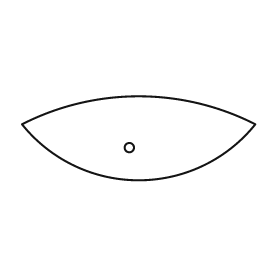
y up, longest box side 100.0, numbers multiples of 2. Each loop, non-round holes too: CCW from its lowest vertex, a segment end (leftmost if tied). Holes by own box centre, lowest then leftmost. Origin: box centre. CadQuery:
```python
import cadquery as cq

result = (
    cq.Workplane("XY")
    .moveTo(-50.0, 6.0)
    .threePointArc((0.0, -18.0), (50.0, 6.0))
    .threePointArc((0.0, 18.0), (-50.0, 6.0))
    .close()
    .moveTo(-4.0, -4.0)
    .circle(2.0)
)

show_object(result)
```